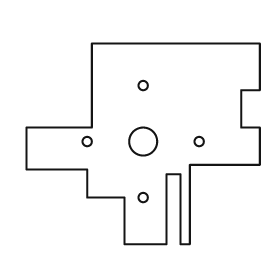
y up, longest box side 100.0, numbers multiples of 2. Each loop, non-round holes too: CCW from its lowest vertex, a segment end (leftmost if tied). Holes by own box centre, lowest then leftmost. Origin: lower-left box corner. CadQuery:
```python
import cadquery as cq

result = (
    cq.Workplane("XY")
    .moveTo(42.0, 0.0)
    .lineTo(60.0, 0.0)
    .lineTo(60.0, 30.0)
    .lineTo(66.0, 30.0)
    .lineTo(66.0, 0.0)
    .lineTo(70.0, 0.0)
    .lineTo(70.0, 34.0)
    .lineTo(100.0, 34.0)
    .lineTo(100.0, 50.0)
    .lineTo(92.0, 50.0)
    .lineTo(92.0, 66.0)
    .lineTo(100.0, 66.0)
    .lineTo(100.0, 86.0)
    .lineTo(28.0, 86.0)
    .lineTo(28.0, 50.0)
    .lineTo(0.0, 50.0)
    .lineTo(0.0, 32.0)
    .lineTo(26.0, 32.0)
    .lineTo(26.0, 20.0)
    .lineTo(42.0, 20.0)
    .close()
    .moveTo(50.0, 20.0)
    .circle(2.0)
    .moveTo(26.0, 44.0)
    .circle(2.0)
    .moveTo(50.0, 44.0)
    .circle(6.0)
    .moveTo(74.0, 44.0)
    .circle(2.0)
    .moveTo(50.0, 68.0)
    .circle(2.0)
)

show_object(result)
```